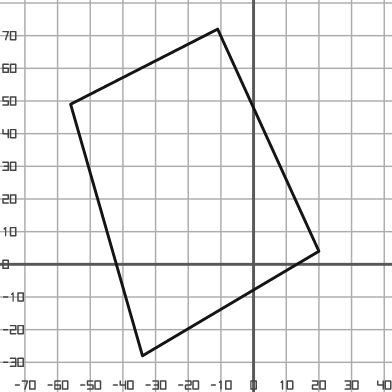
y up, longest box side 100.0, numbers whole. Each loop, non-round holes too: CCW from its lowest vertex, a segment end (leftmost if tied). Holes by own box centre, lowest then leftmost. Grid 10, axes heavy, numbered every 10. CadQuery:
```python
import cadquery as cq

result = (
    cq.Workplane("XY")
    .moveTo(-34.0, -28.0)
    .lineTo(20.0, 4.0)
    .lineTo(-11.0, 72.0)
    .lineTo(-56.0, 49.0)
    .close()
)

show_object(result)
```